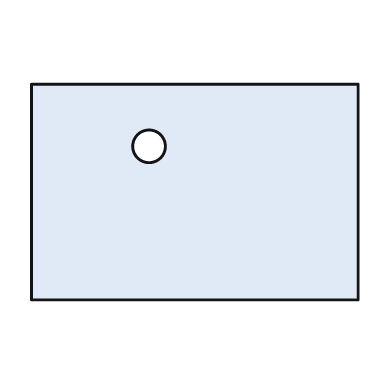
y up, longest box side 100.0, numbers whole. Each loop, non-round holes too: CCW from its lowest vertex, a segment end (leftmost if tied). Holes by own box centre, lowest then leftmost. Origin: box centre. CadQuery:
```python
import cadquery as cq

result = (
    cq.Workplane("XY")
    .moveTo(-50.0, -33.0)
    .lineTo(50.0, -33.0)
    .lineTo(50.0, 33.0)
    .lineTo(-50.0, 33.0)
    .close()
    .moveTo(-14.0, 14.0)
    .circle(5.0)
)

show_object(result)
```